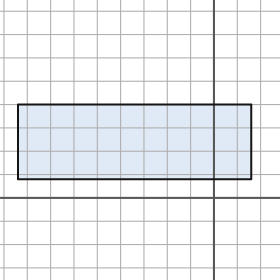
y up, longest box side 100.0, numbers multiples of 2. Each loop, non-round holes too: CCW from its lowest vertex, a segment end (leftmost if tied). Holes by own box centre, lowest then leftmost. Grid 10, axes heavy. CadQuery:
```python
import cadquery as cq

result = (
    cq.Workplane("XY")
    .moveTo(-84.0, 8.0)
    .lineTo(16.0, 8.0)
    .lineTo(16.0, 40.0)
    .lineTo(-84.0, 40.0)
    .close()
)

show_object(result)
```